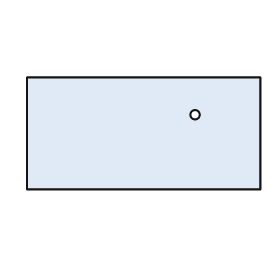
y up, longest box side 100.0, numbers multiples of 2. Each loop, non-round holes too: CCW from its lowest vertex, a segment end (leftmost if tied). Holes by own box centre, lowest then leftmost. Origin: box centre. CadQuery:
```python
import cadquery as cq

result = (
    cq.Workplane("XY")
    .moveTo(-50.0, -24.0)
    .lineTo(50.0, -24.0)
    .lineTo(50.0, 24.0)
    .lineTo(-50.0, 24.0)
    .close()
    .moveTo(22.0, 8.0)
    .circle(2.0)
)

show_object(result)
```